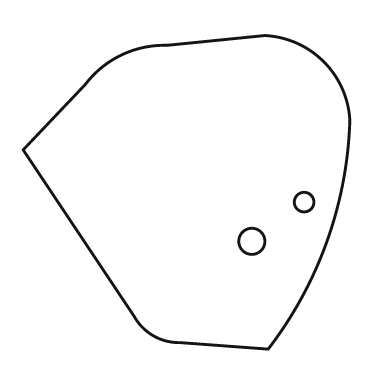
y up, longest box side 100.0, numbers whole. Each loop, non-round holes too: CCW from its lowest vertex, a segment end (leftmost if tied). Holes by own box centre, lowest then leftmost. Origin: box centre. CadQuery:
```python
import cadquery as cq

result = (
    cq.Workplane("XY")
    .moveTo(25.0, -48.0)
    .threePointArc((43.0, -15.0), (50.0, 22.0))
    .threePointArc((42.0, 40.0), (24.0, 48.0))
    .lineTo(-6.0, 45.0)
    .threePointArc((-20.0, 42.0), (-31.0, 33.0))
    .lineTo(-50.0, 13.0)
    .lineTo(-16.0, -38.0)
    .threePointArc((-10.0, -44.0), (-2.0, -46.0))
    .close()
    .moveTo(20.0, -15.0)
    .circle(4.0)
    .moveTo(36.0, -3.0)
    .circle(3.0)
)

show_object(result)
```